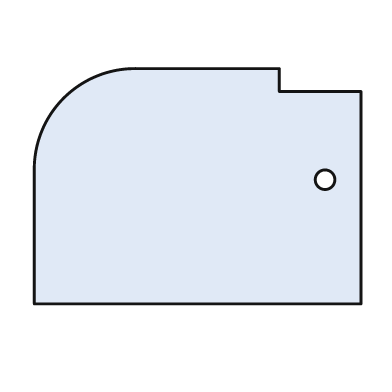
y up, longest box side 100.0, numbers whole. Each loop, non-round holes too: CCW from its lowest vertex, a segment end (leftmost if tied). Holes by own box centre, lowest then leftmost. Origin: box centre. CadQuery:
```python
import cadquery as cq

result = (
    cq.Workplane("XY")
    .moveTo(-50.0, -36.0)
    .lineTo(50.0, -36.0)
    .lineTo(50.0, 29.0)
    .lineTo(25.0, 29.0)
    .lineTo(25.0, 36.0)
    .lineTo(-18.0, 36.0)
    .threePointArc((-41.0, 27.0), (-50.0, 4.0))
    .close()
    .moveTo(39.0, 2.0)
    .circle(3.0)
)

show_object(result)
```